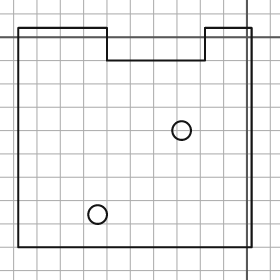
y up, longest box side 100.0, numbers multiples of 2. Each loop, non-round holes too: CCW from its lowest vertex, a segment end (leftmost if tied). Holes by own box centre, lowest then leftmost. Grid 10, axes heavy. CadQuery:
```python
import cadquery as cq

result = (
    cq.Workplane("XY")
    .moveTo(-98.0, -90.0)
    .lineTo(2.0, -90.0)
    .lineTo(2.0, 4.0)
    .lineTo(-18.0, 4.0)
    .lineTo(-18.0, -10.0)
    .lineTo(-60.0, -10.0)
    .lineTo(-60.0, 4.0)
    .lineTo(-98.0, 4.0)
    .close()
    .moveTo(-64.0, -76.0)
    .circle(4.0)
    .moveTo(-28.0, -40.0)
    .circle(4.0)
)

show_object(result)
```